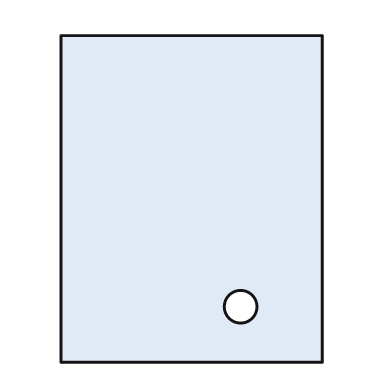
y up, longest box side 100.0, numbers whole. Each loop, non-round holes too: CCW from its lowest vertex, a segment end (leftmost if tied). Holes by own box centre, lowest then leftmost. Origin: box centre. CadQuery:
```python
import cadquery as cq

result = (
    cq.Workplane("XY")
    .moveTo(-40.0, -50.0)
    .lineTo(40.0, -50.0)
    .lineTo(40.0, 50.0)
    .lineTo(-40.0, 50.0)
    .close()
    .moveTo(15.0, -33.0)
    .circle(5.0)
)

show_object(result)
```